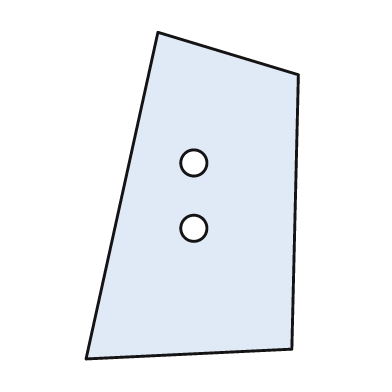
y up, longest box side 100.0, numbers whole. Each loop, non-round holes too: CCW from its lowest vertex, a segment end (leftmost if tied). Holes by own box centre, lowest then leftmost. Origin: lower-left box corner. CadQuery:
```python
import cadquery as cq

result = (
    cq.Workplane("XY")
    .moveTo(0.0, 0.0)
    .lineTo(63.0, 3.0)
    .lineTo(65.0, 87.0)
    .lineTo(22.0, 100.0)
    .close()
    .moveTo(33.0, 40.0)
    .circle(4.0)
    .moveTo(33.0, 60.0)
    .circle(4.0)
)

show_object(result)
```